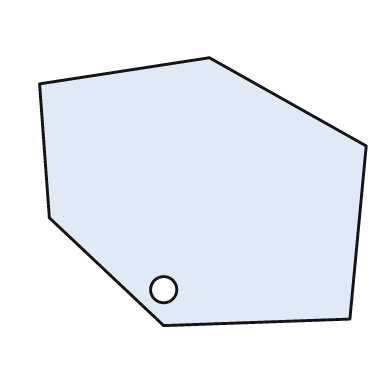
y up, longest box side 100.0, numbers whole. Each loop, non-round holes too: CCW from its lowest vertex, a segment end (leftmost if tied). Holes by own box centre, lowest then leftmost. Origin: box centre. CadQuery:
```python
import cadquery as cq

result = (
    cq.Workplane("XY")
    .moveTo(-12.0, -41.0)
    .lineTo(45.0, -39.0)
    .lineTo(50.0, 14.0)
    .lineTo(2.0, 41.0)
    .lineTo(-50.0, 33.0)
    .lineTo(-47.0, -8.0)
    .close()
    .moveTo(-12.0, -30.0)
    .circle(4.0)
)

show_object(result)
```